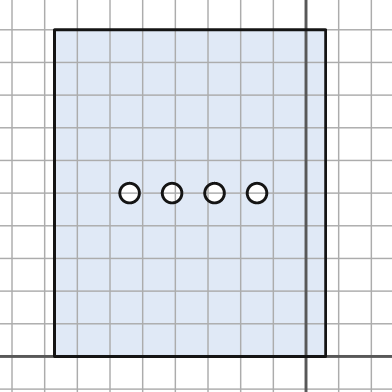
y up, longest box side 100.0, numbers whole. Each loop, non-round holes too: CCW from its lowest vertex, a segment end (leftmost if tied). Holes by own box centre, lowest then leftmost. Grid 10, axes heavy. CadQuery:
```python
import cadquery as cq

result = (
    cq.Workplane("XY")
    .moveTo(-77.0, 0.0)
    .lineTo(6.0, 0.0)
    .lineTo(6.0, 100.0)
    .lineTo(-77.0, 100.0)
    .close()
    .moveTo(-54.0, 50.0)
    .circle(3.0)
    .moveTo(-41.0, 50.0)
    .circle(3.0)
    .moveTo(-28.0, 50.0)
    .circle(3.0)
    .moveTo(-15.0, 50.0)
    .circle(3.0)
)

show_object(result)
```